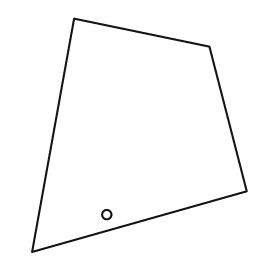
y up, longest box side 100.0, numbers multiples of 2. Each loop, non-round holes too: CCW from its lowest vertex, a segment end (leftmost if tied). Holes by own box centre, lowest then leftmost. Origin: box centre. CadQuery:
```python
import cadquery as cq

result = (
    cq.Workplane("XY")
    .moveTo(-46.0, -50.0)
    .lineTo(46.0, -24.0)
    .lineTo(30.0, 38.0)
    .lineTo(-28.0, 50.0)
    .close()
    .moveTo(-14.0, -34.0)
    .circle(2.0)
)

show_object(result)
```